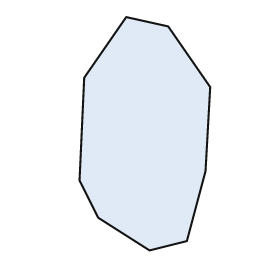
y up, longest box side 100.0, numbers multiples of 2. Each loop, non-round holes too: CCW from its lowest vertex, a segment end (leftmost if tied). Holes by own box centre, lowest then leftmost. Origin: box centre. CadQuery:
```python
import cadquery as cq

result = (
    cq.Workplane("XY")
    .moveTo(2.0, -50.0)
    .lineTo(18.0, -46.0)
    .lineTo(26.0, -16.0)
    .lineTo(28.0, 20.0)
    .lineTo(10.0, 46.0)
    .lineTo(-8.0, 50.0)
    .lineTo(-26.0, 24.0)
    .lineTo(-28.0, -20.0)
    .lineTo(-20.0, -36.0)
    .close()
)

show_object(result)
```